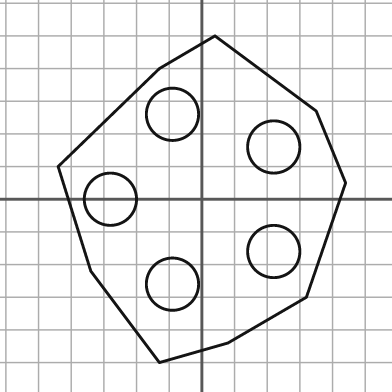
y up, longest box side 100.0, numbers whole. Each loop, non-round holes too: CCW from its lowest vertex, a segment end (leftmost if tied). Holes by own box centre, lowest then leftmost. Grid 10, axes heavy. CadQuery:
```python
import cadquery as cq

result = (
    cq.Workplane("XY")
    .moveTo(-13.0, -50.0)
    .lineTo(8.0, -44.0)
    .lineTo(32.0, -30.0)
    .lineTo(44.0, 5.0)
    .lineTo(35.0, 27.0)
    .lineTo(4.0, 50.0)
    .lineTo(-13.0, 40.0)
    .lineTo(-44.0, 10.0)
    .lineTo(-34.0, -22.0)
    .close()
    .moveTo(-9.0, -26.0)
    .circle(8.0)
    .moveTo(22.0, -16.0)
    .circle(8.0)
    .moveTo(-28.0, 0.0)
    .circle(8.0)
    .moveTo(22.0, 16.0)
    .circle(8.0)
    .moveTo(-9.0, 26.0)
    .circle(8.0)
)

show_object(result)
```